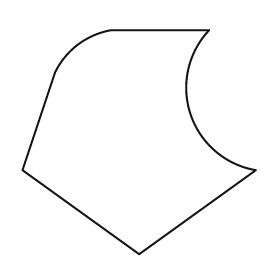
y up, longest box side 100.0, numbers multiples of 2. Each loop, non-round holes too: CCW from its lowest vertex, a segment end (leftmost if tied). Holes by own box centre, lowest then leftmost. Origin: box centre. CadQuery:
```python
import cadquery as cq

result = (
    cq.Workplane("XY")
    .moveTo(0.0, -48.0)
    .lineTo(50.0, -12.0)
    .threePointArc((22.0, 12.0), (30.0, 48.0))
    .lineTo(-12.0, 48.0)
    .threePointArc((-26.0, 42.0), (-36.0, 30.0))
    .lineTo(-50.0, -12.0)
    .close()
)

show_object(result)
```